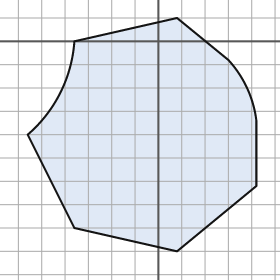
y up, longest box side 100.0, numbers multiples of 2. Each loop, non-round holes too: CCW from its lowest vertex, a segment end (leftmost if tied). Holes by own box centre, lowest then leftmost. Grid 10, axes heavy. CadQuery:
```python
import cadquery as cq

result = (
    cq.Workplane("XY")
    .moveTo(8.0, -90.0)
    .lineTo(42.0, -62.0)
    .lineTo(42.0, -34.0)
    .threePointArc((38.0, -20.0), (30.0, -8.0))
    .lineTo(8.0, 10.0)
    .lineTo(-36.0, 0.0)
    .threePointArc((-42.0, -22.0), (-56.0, -40.0))
    .lineTo(-36.0, -80.0)
    .close()
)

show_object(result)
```